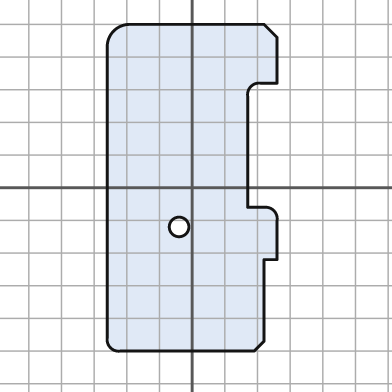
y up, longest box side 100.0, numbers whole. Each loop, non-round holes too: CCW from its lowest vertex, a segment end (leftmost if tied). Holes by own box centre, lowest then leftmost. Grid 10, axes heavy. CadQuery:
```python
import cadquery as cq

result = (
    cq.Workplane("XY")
    .moveTo(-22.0, -50.0)
    .lineTo(19.0, -50.0)
    .lineTo(22.0, -47.0)
    .lineTo(22.0, -22.0)
    .lineTo(26.0, -22.0)
    .lineTo(26.0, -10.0)
    .threePointArc((25.0, -7.0), (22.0, -6.0))
    .lineTo(17.0, -6.0)
    .lineTo(17.0, 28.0)
    .threePointArc((18.0, 31.0), (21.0, 32.0))
    .lineTo(26.0, 32.0)
    .lineTo(26.0, 46.0)
    .lineTo(22.0, 50.0)
    .lineTo(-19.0, 50.0)
    .threePointArc((-24.0, 48.0), (-26.0, 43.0))
    .lineTo(-26.0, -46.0)
    .threePointArc((-25.0, -49.0), (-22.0, -50.0))
    .close()
    .moveTo(-4.0, -12.0)
    .circle(3.0)
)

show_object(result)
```